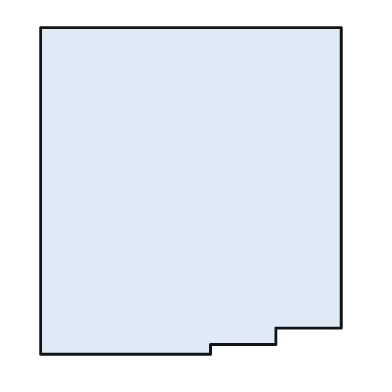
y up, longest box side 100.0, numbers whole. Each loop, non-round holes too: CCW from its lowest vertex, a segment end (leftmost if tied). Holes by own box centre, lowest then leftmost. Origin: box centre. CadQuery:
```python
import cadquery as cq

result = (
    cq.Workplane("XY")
    .moveTo(-46.0, -50.0)
    .lineTo(6.0, -50.0)
    .lineTo(6.0, -47.0)
    .lineTo(26.0, -47.0)
    .lineTo(26.0, -42.0)
    .lineTo(46.0, -42.0)
    .lineTo(46.0, 50.0)
    .lineTo(-46.0, 50.0)
    .close()
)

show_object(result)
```